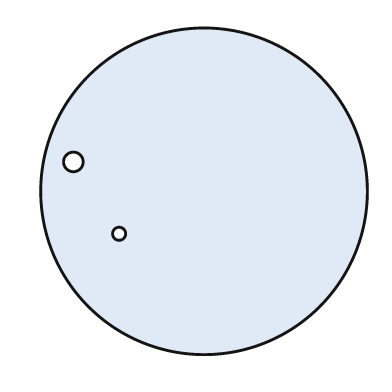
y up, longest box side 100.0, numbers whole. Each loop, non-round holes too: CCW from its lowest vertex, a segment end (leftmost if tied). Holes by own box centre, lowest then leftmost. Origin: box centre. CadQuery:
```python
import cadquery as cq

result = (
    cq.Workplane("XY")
    .moveTo(0.0, 0.0)
    .circle(50.0)
    .moveTo(-26.0, -13.0)
    .circle(2.0)
    .moveTo(-40.0, 9.0)
    .circle(3.0)
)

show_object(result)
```